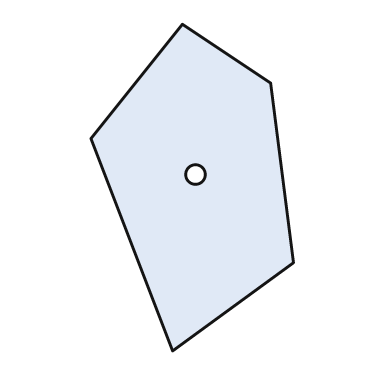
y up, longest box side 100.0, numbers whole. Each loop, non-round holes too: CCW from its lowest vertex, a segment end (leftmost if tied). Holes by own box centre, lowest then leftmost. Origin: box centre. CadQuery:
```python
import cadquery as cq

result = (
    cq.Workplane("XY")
    .moveTo(-6.0, -50.0)
    .lineTo(31.0, -23.0)
    .lineTo(24.0, 32.0)
    .lineTo(-3.0, 50.0)
    .lineTo(-31.0, 15.0)
    .close()
    .moveTo(1.0, 4.0)
    .circle(3.0)
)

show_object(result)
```